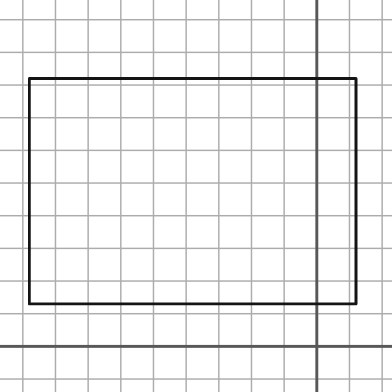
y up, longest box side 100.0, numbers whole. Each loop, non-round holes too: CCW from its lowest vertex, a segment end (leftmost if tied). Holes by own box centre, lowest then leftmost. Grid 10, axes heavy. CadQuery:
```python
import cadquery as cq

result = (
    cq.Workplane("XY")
    .moveTo(-88.0, 13.0)
    .lineTo(12.0, 13.0)
    .lineTo(12.0, 82.0)
    .lineTo(-88.0, 82.0)
    .close()
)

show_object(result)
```